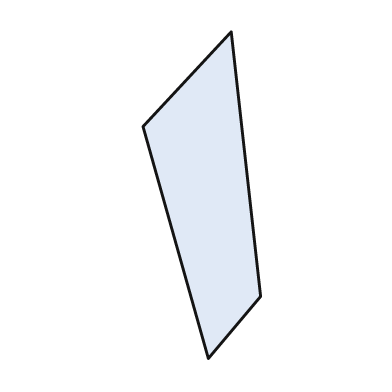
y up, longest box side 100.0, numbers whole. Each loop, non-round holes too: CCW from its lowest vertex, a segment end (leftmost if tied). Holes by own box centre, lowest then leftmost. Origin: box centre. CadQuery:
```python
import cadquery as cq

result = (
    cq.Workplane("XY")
    .moveTo(2.0, -50.0)
    .lineTo(18.0, -31.0)
    .lineTo(9.0, 50.0)
    .lineTo(-18.0, 21.0)
    .close()
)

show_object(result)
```